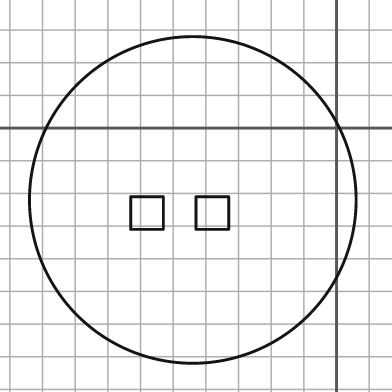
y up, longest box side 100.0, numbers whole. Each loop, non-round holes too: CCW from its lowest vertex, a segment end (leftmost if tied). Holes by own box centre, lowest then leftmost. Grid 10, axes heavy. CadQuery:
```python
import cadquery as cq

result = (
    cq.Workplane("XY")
    .moveTo(-44.0, -22.0)
    .circle(50.0)
    .moveTo(-63.0, -31.0)
    .lineTo(-53.0, -31.0)
    .lineTo(-53.0, -21.0)
    .lineTo(-63.0, -21.0)
    .close()
    .moveTo(-43.0, -31.0)
    .lineTo(-33.0, -31.0)
    .lineTo(-33.0, -21.0)
    .lineTo(-43.0, -21.0)
    .close()
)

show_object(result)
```